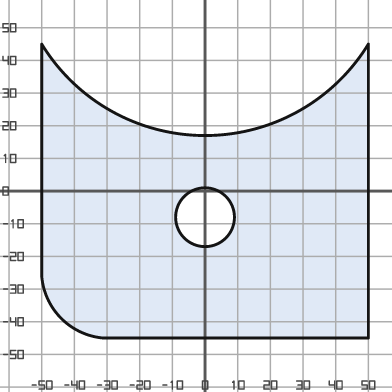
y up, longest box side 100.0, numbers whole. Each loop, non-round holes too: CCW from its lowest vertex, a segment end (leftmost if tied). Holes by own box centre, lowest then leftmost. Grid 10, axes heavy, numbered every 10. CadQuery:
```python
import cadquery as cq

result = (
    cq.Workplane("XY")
    .moveTo(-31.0, -45.0)
    .lineTo(50.0, -45.0)
    .lineTo(50.0, 45.0)
    .threePointArc((0.0, 17.0), (-50.0, 45.0))
    .lineTo(-50.0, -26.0)
    .threePointArc((-44.0, -39.0), (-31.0, -45.0))
    .close()
    .moveTo(0.0, -8.0)
    .circle(9.0)
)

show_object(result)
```